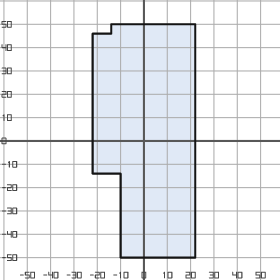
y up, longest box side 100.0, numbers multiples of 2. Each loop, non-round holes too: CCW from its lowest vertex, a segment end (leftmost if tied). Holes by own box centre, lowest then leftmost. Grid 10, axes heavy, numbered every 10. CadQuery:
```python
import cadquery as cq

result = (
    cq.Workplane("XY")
    .moveTo(-10.0, -50.0)
    .lineTo(22.0, -50.0)
    .lineTo(22.0, 50.0)
    .lineTo(-14.0, 50.0)
    .lineTo(-14.0, 46.0)
    .lineTo(-22.0, 46.0)
    .lineTo(-22.0, -14.0)
    .lineTo(-10.0, -14.0)
    .close()
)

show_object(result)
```